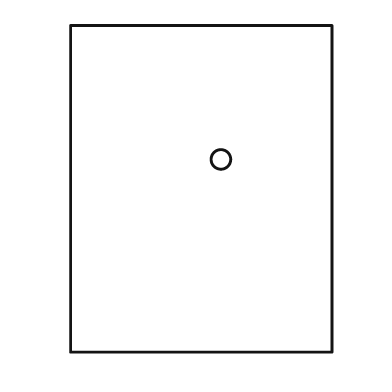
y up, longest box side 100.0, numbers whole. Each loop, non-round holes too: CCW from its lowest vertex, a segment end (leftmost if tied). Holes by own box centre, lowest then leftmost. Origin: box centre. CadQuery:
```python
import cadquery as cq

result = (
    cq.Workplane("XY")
    .moveTo(-40.0, -50.0)
    .lineTo(40.0, -50.0)
    .lineTo(40.0, 50.0)
    .lineTo(-40.0, 50.0)
    .close()
    .moveTo(6.0, 9.0)
    .circle(3.0)
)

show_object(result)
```